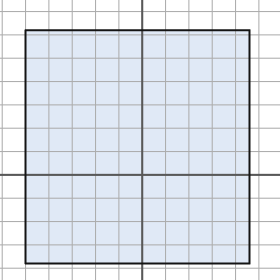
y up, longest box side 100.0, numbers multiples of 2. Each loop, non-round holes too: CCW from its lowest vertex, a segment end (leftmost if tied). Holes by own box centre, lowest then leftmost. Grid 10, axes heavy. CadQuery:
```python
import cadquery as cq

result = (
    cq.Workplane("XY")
    .moveTo(-50.0, -38.0)
    .lineTo(46.0, -38.0)
    .lineTo(46.0, 62.0)
    .lineTo(-50.0, 62.0)
    .close()
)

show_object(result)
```